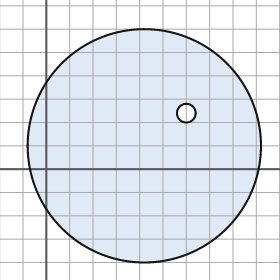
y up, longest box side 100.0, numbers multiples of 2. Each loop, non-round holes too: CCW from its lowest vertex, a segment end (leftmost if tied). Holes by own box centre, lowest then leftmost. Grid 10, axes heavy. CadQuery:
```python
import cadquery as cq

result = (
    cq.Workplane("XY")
    .moveTo(42.0, 10.0)
    .circle(50.0)
    .moveTo(60.0, 24.0)
    .circle(4.0)
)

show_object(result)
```